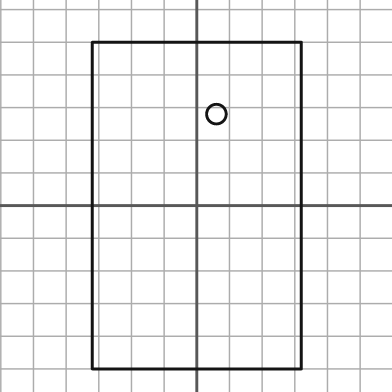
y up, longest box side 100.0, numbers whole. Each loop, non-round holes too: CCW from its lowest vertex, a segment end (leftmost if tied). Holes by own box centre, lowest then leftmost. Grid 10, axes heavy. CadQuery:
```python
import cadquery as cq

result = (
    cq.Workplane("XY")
    .moveTo(-32.0, -50.0)
    .lineTo(32.0, -50.0)
    .lineTo(32.0, 50.0)
    .lineTo(-32.0, 50.0)
    .close()
    .moveTo(6.0, 28.0)
    .circle(3.0)
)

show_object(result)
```